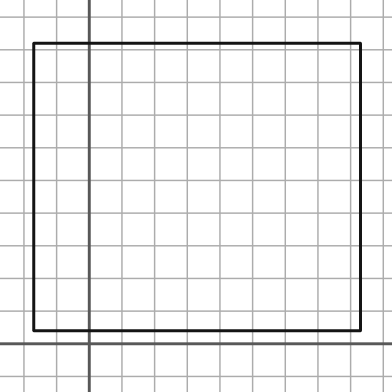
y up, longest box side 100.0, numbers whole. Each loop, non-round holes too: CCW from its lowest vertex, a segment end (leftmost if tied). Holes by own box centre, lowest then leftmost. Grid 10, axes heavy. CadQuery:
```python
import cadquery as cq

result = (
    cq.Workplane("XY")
    .moveTo(-17.0, 4.0)
    .lineTo(83.0, 4.0)
    .lineTo(83.0, 92.0)
    .lineTo(-17.0, 92.0)
    .close()
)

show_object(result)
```